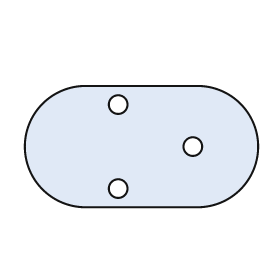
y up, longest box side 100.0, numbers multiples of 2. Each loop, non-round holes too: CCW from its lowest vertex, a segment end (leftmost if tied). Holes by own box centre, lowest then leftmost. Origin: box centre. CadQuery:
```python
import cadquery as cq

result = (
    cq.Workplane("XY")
    .moveTo(-24.0, -26.0)
    .lineTo(24.0, -26.0)
    .threePointArc((50.0, 0.0), (24.0, 26.0))
    .lineTo(-24.0, 26.0)
    .threePointArc((-50.0, 0.0), (-24.0, -26.0))
    .close()
    .moveTo(-10.0, -18.0)
    .circle(4.0)
    .moveTo(22.0, 0.0)
    .circle(4.0)
    .moveTo(-10.0, 18.0)
    .circle(4.0)
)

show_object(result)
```